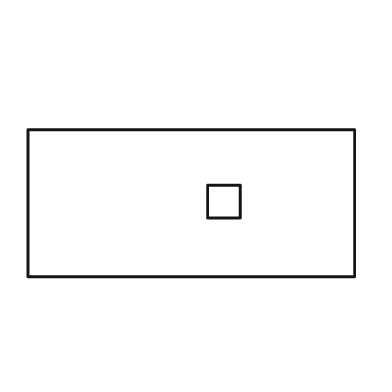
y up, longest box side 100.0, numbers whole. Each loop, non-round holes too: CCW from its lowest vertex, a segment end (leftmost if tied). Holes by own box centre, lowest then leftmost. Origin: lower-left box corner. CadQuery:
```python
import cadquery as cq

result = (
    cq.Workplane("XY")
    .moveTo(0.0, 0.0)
    .lineTo(100.0, 0.0)
    .lineTo(100.0, 45.0)
    .lineTo(0.0, 45.0)
    .close()
    .moveTo(55.0, 18.0)
    .lineTo(65.0, 18.0)
    .lineTo(65.0, 28.0)
    .lineTo(55.0, 28.0)
    .close()
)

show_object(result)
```